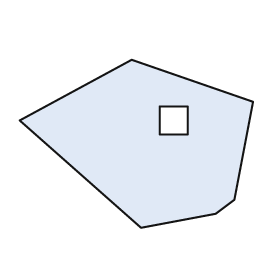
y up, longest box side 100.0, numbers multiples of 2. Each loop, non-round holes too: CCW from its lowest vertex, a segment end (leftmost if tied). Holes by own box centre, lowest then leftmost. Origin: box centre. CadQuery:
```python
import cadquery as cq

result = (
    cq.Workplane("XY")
    .moveTo(2.0, -36.0)
    .lineTo(34.0, -30.0)
    .lineTo(42.0, -24.0)
    .lineTo(50.0, 18.0)
    .lineTo(-2.0, 36.0)
    .lineTo(-50.0, 10.0)
    .close()
    .moveTo(10.0, 4.0)
    .lineTo(22.0, 4.0)
    .lineTo(22.0, 16.0)
    .lineTo(10.0, 16.0)
    .close()
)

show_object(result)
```